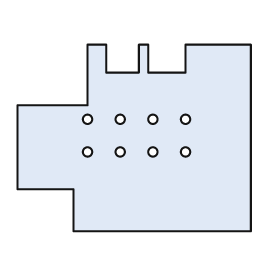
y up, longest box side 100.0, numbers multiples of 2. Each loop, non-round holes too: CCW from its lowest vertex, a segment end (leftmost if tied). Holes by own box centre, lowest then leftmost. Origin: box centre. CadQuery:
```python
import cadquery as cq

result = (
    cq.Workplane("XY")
    .moveTo(-26.0, -40.0)
    .lineTo(50.0, -40.0)
    .lineTo(50.0, 40.0)
    .lineTo(22.0, 40.0)
    .lineTo(22.0, 28.0)
    .lineTo(6.0, 28.0)
    .lineTo(6.0, 40.0)
    .lineTo(2.0, 40.0)
    .lineTo(2.0, 28.0)
    .lineTo(-12.0, 28.0)
    .lineTo(-12.0, 40.0)
    .lineTo(-20.0, 40.0)
    .lineTo(-20.0, 14.0)
    .lineTo(-50.0, 14.0)
    .lineTo(-50.0, -22.0)
    .lineTo(-26.0, -22.0)
    .close()
    .moveTo(-20.0, -6.0)
    .circle(2.0)
    .moveTo(-6.0, -6.0)
    .circle(2.0)
    .moveTo(8.0, -6.0)
    .circle(2.0)
    .moveTo(22.0, -6.0)
    .circle(2.0)
    .moveTo(-20.0, 8.0)
    .circle(2.0)
    .moveTo(-6.0, 8.0)
    .circle(2.0)
    .moveTo(8.0, 8.0)
    .circle(2.0)
    .moveTo(22.0, 8.0)
    .circle(2.0)
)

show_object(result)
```